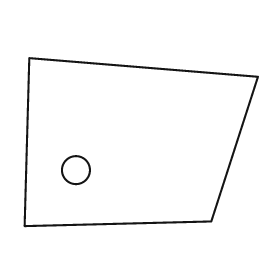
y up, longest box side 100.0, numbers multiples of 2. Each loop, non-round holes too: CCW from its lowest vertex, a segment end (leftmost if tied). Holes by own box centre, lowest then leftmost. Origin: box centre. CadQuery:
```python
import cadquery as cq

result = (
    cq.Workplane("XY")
    .moveTo(-50.0, -36.0)
    .lineTo(30.0, -34.0)
    .lineTo(50.0, 28.0)
    .lineTo(-48.0, 36.0)
    .close()
    .moveTo(-28.0, -12.0)
    .circle(6.0)
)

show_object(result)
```